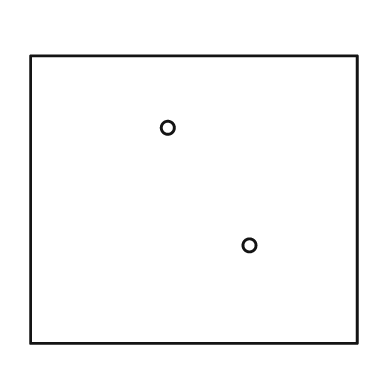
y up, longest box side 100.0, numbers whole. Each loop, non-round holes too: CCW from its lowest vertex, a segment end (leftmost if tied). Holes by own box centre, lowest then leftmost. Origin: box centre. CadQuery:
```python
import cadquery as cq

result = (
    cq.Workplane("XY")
    .moveTo(-50.0, -44.0)
    .lineTo(50.0, -44.0)
    .lineTo(50.0, 44.0)
    .lineTo(-50.0, 44.0)
    .close()
    .moveTo(17.0, -14.0)
    .circle(2.0)
    .moveTo(-8.0, 22.0)
    .circle(2.0)
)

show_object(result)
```